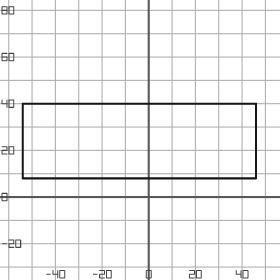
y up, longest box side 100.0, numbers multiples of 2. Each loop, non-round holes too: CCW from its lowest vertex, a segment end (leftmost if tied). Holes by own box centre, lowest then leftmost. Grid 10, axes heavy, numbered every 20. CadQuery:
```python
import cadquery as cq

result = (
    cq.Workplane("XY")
    .moveTo(-54.0, 8.0)
    .lineTo(46.0, 8.0)
    .lineTo(46.0, 40.0)
    .lineTo(-54.0, 40.0)
    .close()
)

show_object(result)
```